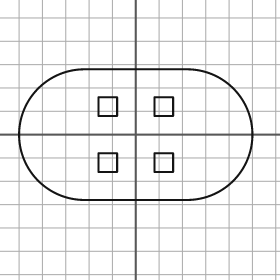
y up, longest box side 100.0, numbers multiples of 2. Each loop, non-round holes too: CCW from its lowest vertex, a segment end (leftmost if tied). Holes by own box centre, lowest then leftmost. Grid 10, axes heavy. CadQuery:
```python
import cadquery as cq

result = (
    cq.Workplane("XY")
    .moveTo(-22.0, -28.0)
    .lineTo(22.0, -28.0)
    .threePointArc((50.0, 0.0), (22.0, 28.0))
    .lineTo(-22.0, 28.0)
    .threePointArc((-50.0, 0.0), (-22.0, -28.0))
    .close()
    .moveTo(-16.0, -16.0)
    .lineTo(-8.0, -16.0)
    .lineTo(-8.0, -8.0)
    .lineTo(-16.0, -8.0)
    .close()
    .moveTo(8.0, -16.0)
    .lineTo(16.0, -16.0)
    .lineTo(16.0, -8.0)
    .lineTo(8.0, -8.0)
    .close()
    .moveTo(-16.0, 8.0)
    .lineTo(-8.0, 8.0)
    .lineTo(-8.0, 16.0)
    .lineTo(-16.0, 16.0)
    .close()
    .moveTo(8.0, 8.0)
    .lineTo(16.0, 8.0)
    .lineTo(16.0, 16.0)
    .lineTo(8.0, 16.0)
    .close()
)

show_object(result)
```